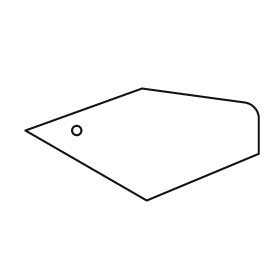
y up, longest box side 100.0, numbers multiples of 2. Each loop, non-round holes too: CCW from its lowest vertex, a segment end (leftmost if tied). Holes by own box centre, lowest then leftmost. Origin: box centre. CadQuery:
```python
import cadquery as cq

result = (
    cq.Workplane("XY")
    .moveTo(2.0, -24.0)
    .lineTo(50.0, -4.0)
    .lineTo(50.0, 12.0)
    .threePointArc((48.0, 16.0), (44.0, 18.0))
    .lineTo(0.0, 24.0)
    .lineTo(-50.0, 6.0)
    .close()
    .moveTo(-28.0, 6.0)
    .circle(2.0)
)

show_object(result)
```